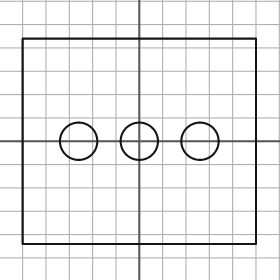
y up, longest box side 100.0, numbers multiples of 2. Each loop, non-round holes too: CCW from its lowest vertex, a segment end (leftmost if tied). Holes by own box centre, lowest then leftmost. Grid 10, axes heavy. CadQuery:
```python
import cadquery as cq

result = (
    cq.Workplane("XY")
    .moveTo(-50.0, -44.0)
    .lineTo(50.0, -44.0)
    .lineTo(50.0, 44.0)
    .lineTo(-50.0, 44.0)
    .close()
    .moveTo(-26.0, 0.0)
    .circle(8.0)
    .moveTo(0.0, 0.0)
    .circle(8.0)
    .moveTo(26.0, 0.0)
    .circle(8.0)
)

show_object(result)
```